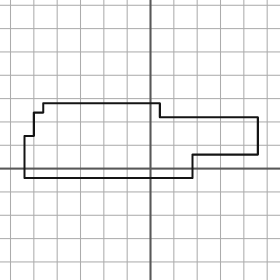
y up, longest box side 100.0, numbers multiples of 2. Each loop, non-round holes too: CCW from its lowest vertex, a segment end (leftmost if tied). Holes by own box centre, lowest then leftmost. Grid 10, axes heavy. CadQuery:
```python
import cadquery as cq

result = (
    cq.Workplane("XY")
    .moveTo(-54.0, -4.0)
    .lineTo(18.0, -4.0)
    .lineTo(18.0, 6.0)
    .lineTo(46.0, 6.0)
    .lineTo(46.0, 22.0)
    .lineTo(4.0, 22.0)
    .lineTo(4.0, 28.0)
    .lineTo(-46.0, 28.0)
    .lineTo(-46.0, 24.0)
    .lineTo(-50.0, 24.0)
    .lineTo(-50.0, 14.0)
    .lineTo(-54.0, 14.0)
    .close()
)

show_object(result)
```